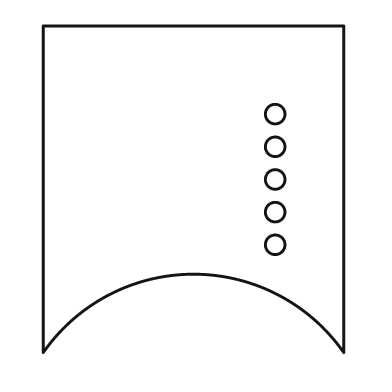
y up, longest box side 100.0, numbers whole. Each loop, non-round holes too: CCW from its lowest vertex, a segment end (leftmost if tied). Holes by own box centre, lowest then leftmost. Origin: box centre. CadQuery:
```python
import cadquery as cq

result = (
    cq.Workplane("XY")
    .moveTo(-46.0, -50.0)
    .threePointArc((0.0, -26.0), (46.0, -50.0))
    .lineTo(46.0, 50.0)
    .lineTo(-46.0, 50.0)
    .close()
    .moveTo(25.0, -17.0)
    .circle(3.0)
    .moveTo(25.0, -7.0)
    .circle(3.0)
    .moveTo(25.0, 3.0)
    .circle(3.0)
    .moveTo(25.0, 13.0)
    .circle(3.0)
    .moveTo(25.0, 23.0)
    .circle(3.0)
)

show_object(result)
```